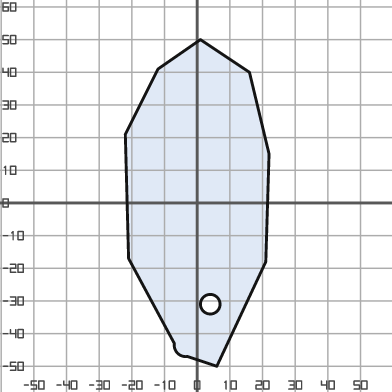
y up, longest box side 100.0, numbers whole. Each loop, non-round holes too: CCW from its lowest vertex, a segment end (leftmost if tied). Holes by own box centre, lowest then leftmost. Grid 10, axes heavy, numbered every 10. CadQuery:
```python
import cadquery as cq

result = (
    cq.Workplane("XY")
    .moveTo(6.0, -50.0)
    .lineTo(21.0, -18.0)
    .lineTo(22.0, 15.0)
    .lineTo(16.0, 40.0)
    .lineTo(1.0, 50.0)
    .lineTo(-12.0, 41.0)
    .lineTo(-22.0, 21.0)
    .lineTo(-21.0, -17.0)
    .lineTo(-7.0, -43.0)
    .threePointArc((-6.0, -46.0), (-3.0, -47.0))
    .close()
    .moveTo(4.0, -31.0)
    .circle(3.0)
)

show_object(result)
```